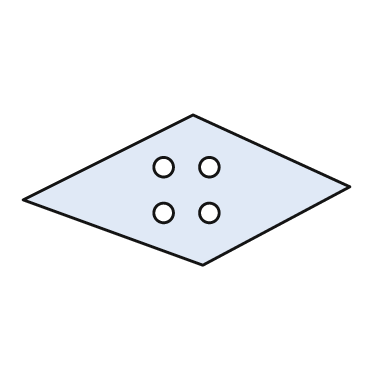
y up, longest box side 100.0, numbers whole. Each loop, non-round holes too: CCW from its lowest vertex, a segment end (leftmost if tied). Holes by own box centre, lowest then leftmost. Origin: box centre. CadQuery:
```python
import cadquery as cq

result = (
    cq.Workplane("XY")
    .moveTo(5.0, -23.0)
    .lineTo(50.0, 1.0)
    .lineTo(2.0, 23.0)
    .lineTo(-50.0, -3.0)
    .close()
    .moveTo(-7.0, -7.0)
    .circle(3.0)
    .moveTo(7.0, -7.0)
    .circle(3.0)
    .moveTo(-7.0, 7.0)
    .circle(3.0)
    .moveTo(7.0, 7.0)
    .circle(3.0)
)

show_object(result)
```